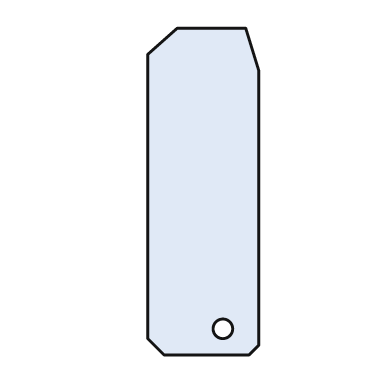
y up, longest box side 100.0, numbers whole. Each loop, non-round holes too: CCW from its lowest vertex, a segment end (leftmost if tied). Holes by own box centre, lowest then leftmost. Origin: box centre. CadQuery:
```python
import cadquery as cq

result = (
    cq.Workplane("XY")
    .moveTo(-12.0, -50.0)
    .lineTo(14.0, -50.0)
    .lineTo(17.0, -47.0)
    .lineTo(17.0, 37.0)
    .lineTo(13.0, 50.0)
    .lineTo(-8.0, 50.0)
    .lineTo(-17.0, 42.0)
    .lineTo(-17.0, -45.0)
    .close()
    .moveTo(6.0, -42.0)
    .circle(3.0)
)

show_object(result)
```